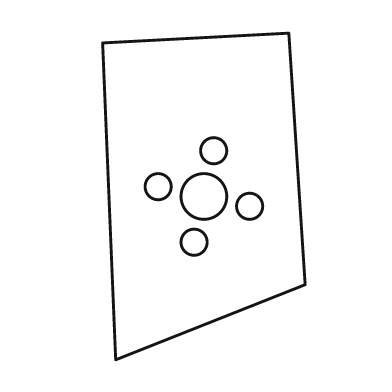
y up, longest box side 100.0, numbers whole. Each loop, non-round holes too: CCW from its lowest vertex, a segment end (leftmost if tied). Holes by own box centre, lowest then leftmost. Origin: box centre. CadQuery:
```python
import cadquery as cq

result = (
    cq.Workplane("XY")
    .moveTo(-27.0, -50.0)
    .lineTo(31.0, -27.0)
    .lineTo(26.0, 50.0)
    .lineTo(-31.0, 47.0)
    .close()
    .moveTo(-3.0, -14.0)
    .circle(4.0)
    .moveTo(14.0, -3.0)
    .circle(4.0)
    .moveTo(0.0, 0.0)
    .circle(7.0)
    .moveTo(-14.0, 3.0)
    .circle(4.0)
    .moveTo(3.0, 14.0)
    .circle(4.0)
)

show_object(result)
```